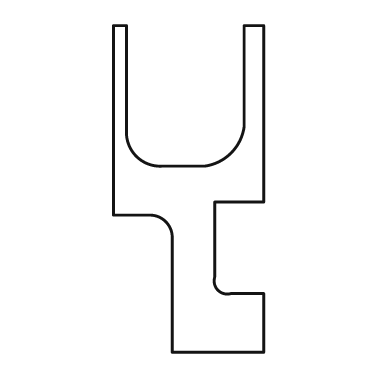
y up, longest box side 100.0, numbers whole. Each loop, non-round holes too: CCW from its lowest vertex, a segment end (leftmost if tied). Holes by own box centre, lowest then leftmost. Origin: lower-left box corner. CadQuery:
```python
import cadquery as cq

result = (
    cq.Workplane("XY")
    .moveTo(18.0, 0.0)
    .lineTo(46.0, 0.0)
    .lineTo(46.0, 18.0)
    .lineTo(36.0, 18.0)
    .threePointArc((32.0, 19.0), (31.0, 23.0))
    .lineTo(31.0, 46.0)
    .lineTo(46.0, 46.0)
    .lineTo(46.0, 100.0)
    .lineTo(40.0, 100.0)
    .lineTo(40.0, 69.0)
    .threePointArc((36.0, 61.0), (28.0, 57.0))
    .lineTo(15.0, 57.0)
    .threePointArc((7.0, 60.0), (4.0, 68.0))
    .lineTo(4.0, 100.0)
    .lineTo(0.0, 100.0)
    .lineTo(0.0, 42.0)
    .lineTo(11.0, 42.0)
    .threePointArc((16.0, 40.0), (18.0, 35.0))
    .close()
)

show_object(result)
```